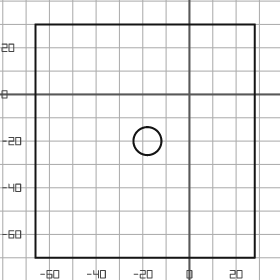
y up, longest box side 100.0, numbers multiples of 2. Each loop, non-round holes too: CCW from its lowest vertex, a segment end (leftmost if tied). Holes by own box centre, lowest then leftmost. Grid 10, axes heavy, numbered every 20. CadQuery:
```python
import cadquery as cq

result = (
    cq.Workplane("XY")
    .moveTo(-66.0, -70.0)
    .lineTo(28.0, -70.0)
    .lineTo(28.0, 30.0)
    .lineTo(-66.0, 30.0)
    .close()
    .moveTo(-18.0, -20.0)
    .circle(6.0)
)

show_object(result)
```